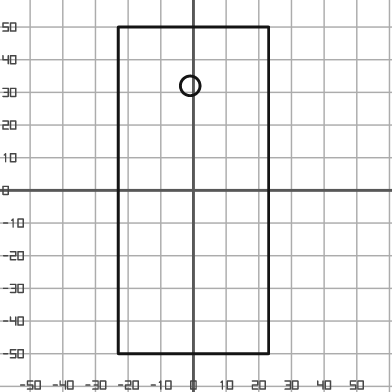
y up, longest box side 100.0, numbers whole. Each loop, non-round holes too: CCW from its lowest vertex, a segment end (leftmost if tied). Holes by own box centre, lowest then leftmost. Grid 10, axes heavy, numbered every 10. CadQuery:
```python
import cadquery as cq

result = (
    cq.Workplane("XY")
    .moveTo(-23.0, -50.0)
    .lineTo(23.0, -50.0)
    .lineTo(23.0, 50.0)
    .lineTo(-23.0, 50.0)
    .close()
    .moveTo(-1.0, 32.0)
    .circle(3.0)
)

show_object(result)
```